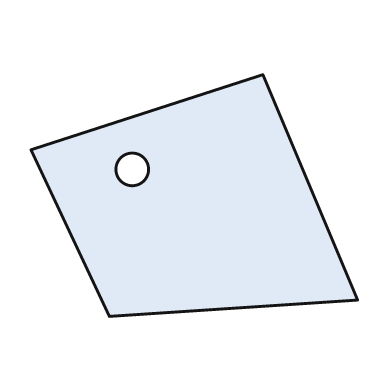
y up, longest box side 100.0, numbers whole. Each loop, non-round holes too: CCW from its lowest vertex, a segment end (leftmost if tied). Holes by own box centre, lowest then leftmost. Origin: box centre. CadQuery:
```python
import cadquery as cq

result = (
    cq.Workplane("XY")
    .moveTo(-26.0, -37.0)
    .lineTo(50.0, -32.0)
    .lineTo(21.0, 37.0)
    .lineTo(-50.0, 14.0)
    .close()
    .moveTo(-19.0, 8.0)
    .circle(5.0)
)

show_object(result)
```